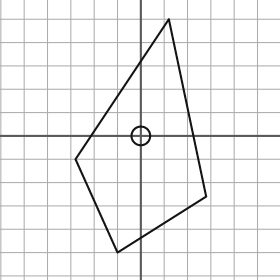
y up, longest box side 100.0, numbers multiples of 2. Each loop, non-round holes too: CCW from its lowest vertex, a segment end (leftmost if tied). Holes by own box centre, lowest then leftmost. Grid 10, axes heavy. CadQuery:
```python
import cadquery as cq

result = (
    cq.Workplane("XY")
    .moveTo(-10.0, -50.0)
    .lineTo(28.0, -26.0)
    .lineTo(12.0, 50.0)
    .lineTo(-28.0, -10.0)
    .close()
    .moveTo(0.0, 0.0)
    .circle(4.0)
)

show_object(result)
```